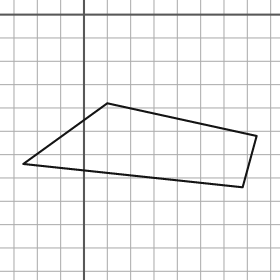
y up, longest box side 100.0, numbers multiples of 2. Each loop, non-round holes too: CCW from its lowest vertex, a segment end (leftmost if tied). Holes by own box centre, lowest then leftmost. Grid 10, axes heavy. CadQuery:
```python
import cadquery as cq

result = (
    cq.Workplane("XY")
    .moveTo(68.0, -74.0)
    .lineTo(74.0, -52.0)
    .lineTo(10.0, -38.0)
    .lineTo(-26.0, -64.0)
    .close()
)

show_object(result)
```